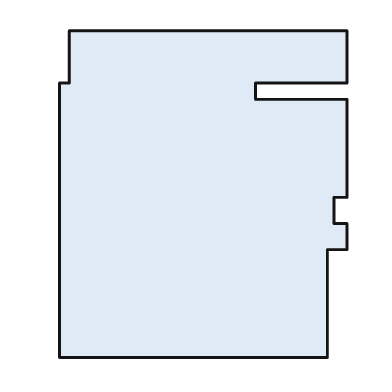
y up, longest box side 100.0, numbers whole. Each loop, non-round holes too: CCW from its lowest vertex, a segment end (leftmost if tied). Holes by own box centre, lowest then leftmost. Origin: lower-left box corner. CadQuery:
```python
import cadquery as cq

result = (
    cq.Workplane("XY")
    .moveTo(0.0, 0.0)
    .lineTo(82.0, 0.0)
    .lineTo(82.0, 33.0)
    .lineTo(88.0, 33.0)
    .lineTo(88.0, 41.0)
    .lineTo(84.0, 41.0)
    .lineTo(84.0, 49.0)
    .lineTo(88.0, 49.0)
    .lineTo(88.0, 79.0)
    .lineTo(60.0, 79.0)
    .lineTo(60.0, 84.0)
    .lineTo(88.0, 84.0)
    .lineTo(88.0, 100.0)
    .lineTo(3.0, 100.0)
    .lineTo(3.0, 84.0)
    .lineTo(0.0, 84.0)
    .close()
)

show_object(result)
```